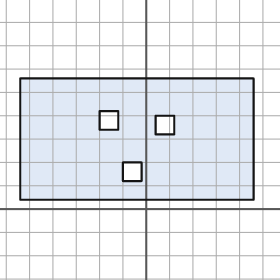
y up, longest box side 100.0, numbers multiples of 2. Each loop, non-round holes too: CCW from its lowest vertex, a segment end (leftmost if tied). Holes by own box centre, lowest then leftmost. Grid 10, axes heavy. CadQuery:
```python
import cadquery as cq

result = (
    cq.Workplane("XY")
    .moveTo(-54.0, 4.0)
    .lineTo(46.0, 4.0)
    .lineTo(46.0, 56.0)
    .lineTo(-54.0, 56.0)
    .close()
    .moveTo(-10.0, 12.0)
    .lineTo(-2.0, 12.0)
    .lineTo(-2.0, 20.0)
    .lineTo(-10.0, 20.0)
    .close()
    .moveTo(4.0, 32.0)
    .lineTo(12.0, 32.0)
    .lineTo(12.0, 40.0)
    .lineTo(4.0, 40.0)
    .close()
    .moveTo(-20.0, 34.0)
    .lineTo(-12.0, 34.0)
    .lineTo(-12.0, 42.0)
    .lineTo(-20.0, 42.0)
    .close()
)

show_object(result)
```